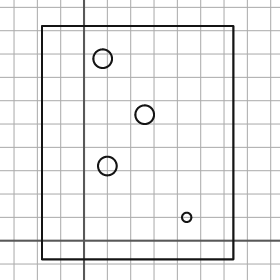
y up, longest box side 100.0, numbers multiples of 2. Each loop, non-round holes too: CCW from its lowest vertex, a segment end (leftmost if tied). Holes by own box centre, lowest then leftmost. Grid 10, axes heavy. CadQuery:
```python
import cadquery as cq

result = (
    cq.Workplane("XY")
    .moveTo(-18.0, -8.0)
    .lineTo(64.0, -8.0)
    .lineTo(64.0, 92.0)
    .lineTo(-18.0, 92.0)
    .close()
    .moveTo(44.0, 10.0)
    .circle(2.0)
    .moveTo(10.0, 32.0)
    .circle(4.0)
    .moveTo(26.0, 54.0)
    .circle(4.0)
    .moveTo(8.0, 78.0)
    .circle(4.0)
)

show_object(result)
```